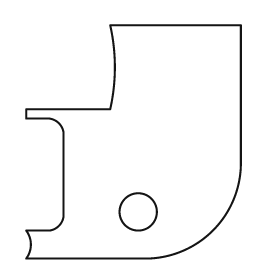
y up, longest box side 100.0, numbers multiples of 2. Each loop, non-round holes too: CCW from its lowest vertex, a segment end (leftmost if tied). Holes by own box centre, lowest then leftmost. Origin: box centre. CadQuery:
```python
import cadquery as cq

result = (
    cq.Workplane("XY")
    .moveTo(-46.0, -50.0)
    .lineTo(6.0, -50.0)
    .threePointArc((34.0, -38.0), (46.0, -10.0))
    .lineTo(46.0, 50.0)
    .lineTo(-10.0, 50.0)
    .threePointArc((-8.0, 32.0), (-10.0, 14.0))
    .lineTo(-46.0, 14.0)
    .lineTo(-46.0, 10.0)
    .lineTo(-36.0, 10.0)
    .threePointArc((-32.0, 8.0), (-30.0, 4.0))
    .lineTo(-30.0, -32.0)
    .threePointArc((-32.0, -36.0), (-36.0, -38.0))
    .lineTo(-46.0, -38.0)
    .threePointArc((-44.0, -44.0), (-46.0, -50.0))
    .close()
    .moveTo(2.0, -30.0)
    .circle(8.0)
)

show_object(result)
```